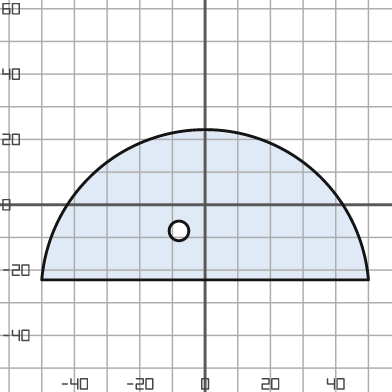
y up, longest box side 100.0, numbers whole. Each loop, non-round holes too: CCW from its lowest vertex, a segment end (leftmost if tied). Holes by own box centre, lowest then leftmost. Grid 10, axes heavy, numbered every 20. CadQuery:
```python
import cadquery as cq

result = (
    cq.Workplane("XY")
    .moveTo(-50.0, -23.0)
    .lineTo(50.0, -23.0)
    .threePointArc((0.0, 23.0), (-50.0, -23.0))
    .close()
    .moveTo(-8.0, -8.0)
    .circle(3.0)
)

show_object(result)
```